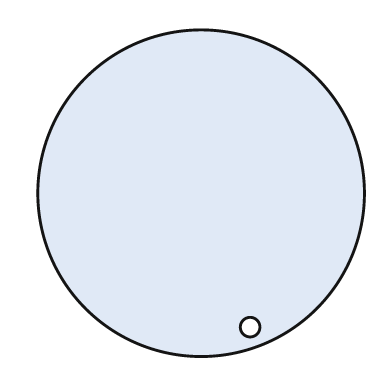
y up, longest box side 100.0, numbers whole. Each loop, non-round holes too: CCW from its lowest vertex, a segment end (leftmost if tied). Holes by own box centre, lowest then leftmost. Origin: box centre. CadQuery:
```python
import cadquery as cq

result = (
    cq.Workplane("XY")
    .moveTo(0.0, 0.0)
    .circle(50.0)
    .moveTo(15.0, -41.0)
    .circle(3.0)
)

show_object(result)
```